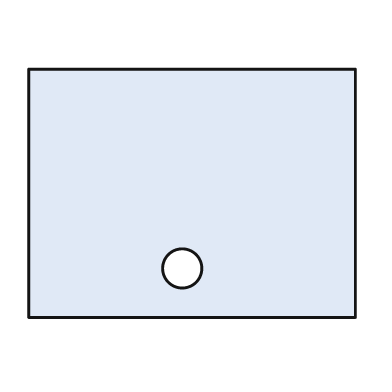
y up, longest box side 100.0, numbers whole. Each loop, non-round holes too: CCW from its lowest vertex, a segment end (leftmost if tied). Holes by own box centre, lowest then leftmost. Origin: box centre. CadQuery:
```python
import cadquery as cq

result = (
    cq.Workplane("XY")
    .moveTo(-50.0, -38.0)
    .lineTo(50.0, -38.0)
    .lineTo(50.0, 38.0)
    .lineTo(-50.0, 38.0)
    .close()
    .moveTo(-3.0, -23.0)
    .circle(6.0)
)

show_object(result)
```